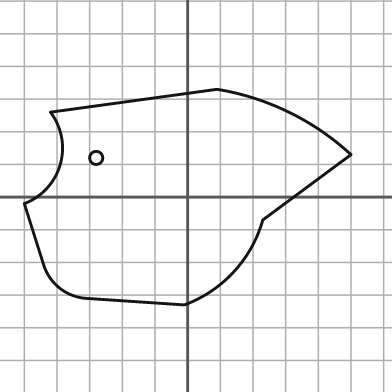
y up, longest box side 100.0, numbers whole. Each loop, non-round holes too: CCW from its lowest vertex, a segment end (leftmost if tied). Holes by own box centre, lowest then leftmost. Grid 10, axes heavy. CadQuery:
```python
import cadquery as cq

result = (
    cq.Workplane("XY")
    .moveTo(-1.0, -33.0)
    .threePointArc((14.0, -23.0), (23.0, -7.0))
    .lineTo(50.0, 13.0)
    .threePointArc((31.0, 26.0), (9.0, 33.0))
    .lineTo(-42.0, 26.0)
    .threePointArc((-39.0, 10.0), (-50.0, -2.0))
    .lineTo(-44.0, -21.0)
    .threePointArc((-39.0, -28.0), (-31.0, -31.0))
    .close()
    .moveTo(-28.0, 12.0)
    .circle(2.0)
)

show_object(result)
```